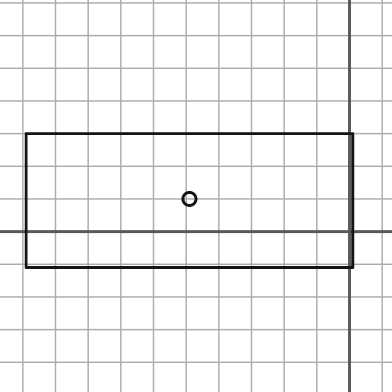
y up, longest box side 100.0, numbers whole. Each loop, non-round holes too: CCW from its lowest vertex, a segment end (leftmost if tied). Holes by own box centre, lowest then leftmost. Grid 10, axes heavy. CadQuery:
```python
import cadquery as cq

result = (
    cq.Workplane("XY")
    .moveTo(-99.0, -11.0)
    .lineTo(1.0, -11.0)
    .lineTo(1.0, 30.0)
    .lineTo(-99.0, 30.0)
    .close()
    .moveTo(-49.0, 10.0)
    .circle(2.0)
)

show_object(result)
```